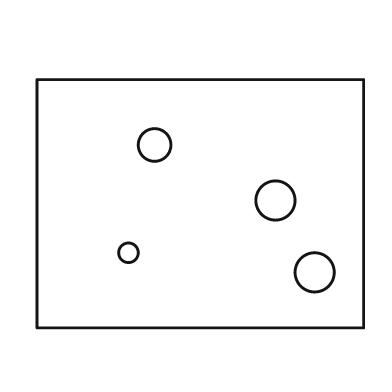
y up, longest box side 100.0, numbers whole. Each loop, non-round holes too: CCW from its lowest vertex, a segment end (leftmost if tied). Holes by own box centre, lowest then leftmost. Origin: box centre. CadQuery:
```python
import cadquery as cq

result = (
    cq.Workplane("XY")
    .moveTo(-50.0, -38.0)
    .lineTo(50.0, -38.0)
    .lineTo(50.0, 38.0)
    .lineTo(-50.0, 38.0)
    .close()
    .moveTo(35.0, -21.0)
    .circle(6.0)
    .moveTo(-22.0, -15.0)
    .circle(3.0)
    .moveTo(23.0, 1.0)
    .circle(6.0)
    .moveTo(-14.0, 18.0)
    .circle(5.0)
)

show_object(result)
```